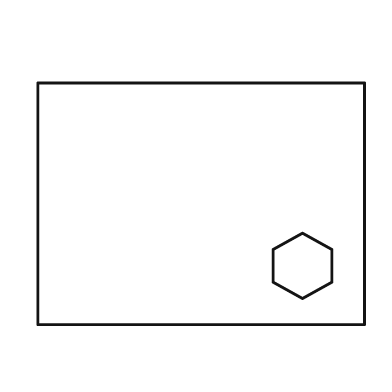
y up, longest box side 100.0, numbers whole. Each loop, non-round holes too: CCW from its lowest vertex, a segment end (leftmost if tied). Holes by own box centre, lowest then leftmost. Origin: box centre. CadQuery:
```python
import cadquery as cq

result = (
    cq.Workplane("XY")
    .moveTo(-50.0, -37.0)
    .lineTo(50.0, -37.0)
    .lineTo(50.0, 37.0)
    .lineTo(-50.0, 37.0)
    .close()
    .moveTo(31.0, -29.0)
    .lineTo(40.0, -24.0)
    .lineTo(40.0, -14.0)
    .lineTo(31.0, -9.0)
    .lineTo(22.0, -14.0)
    .lineTo(22.0, -24.0)
    .close()
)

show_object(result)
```